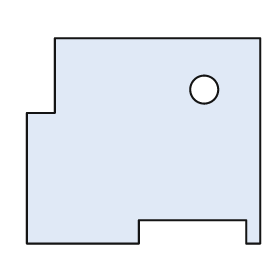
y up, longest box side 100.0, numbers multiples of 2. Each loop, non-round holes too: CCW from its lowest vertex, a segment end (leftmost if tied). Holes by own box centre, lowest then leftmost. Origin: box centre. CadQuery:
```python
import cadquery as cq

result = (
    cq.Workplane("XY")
    .moveTo(-50.0, -44.0)
    .lineTo(-2.0, -44.0)
    .lineTo(-2.0, -34.0)
    .lineTo(44.0, -34.0)
    .lineTo(44.0, -44.0)
    .lineTo(50.0, -44.0)
    .lineTo(50.0, 44.0)
    .lineTo(-38.0, 44.0)
    .lineTo(-38.0, 12.0)
    .lineTo(-50.0, 12.0)
    .close()
    .moveTo(26.0, 22.0)
    .circle(6.0)
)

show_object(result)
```